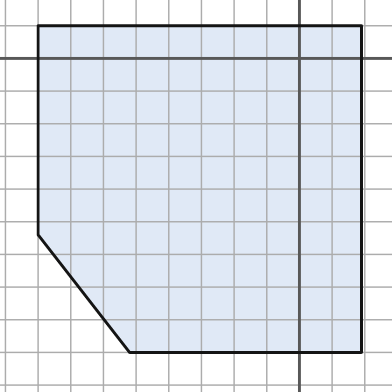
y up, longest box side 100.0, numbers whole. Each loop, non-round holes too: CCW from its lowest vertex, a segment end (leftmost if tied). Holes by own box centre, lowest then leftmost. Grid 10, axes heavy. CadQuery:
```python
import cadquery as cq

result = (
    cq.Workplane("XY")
    .moveTo(-52.0, -90.0)
    .lineTo(19.0, -90.0)
    .lineTo(19.0, 10.0)
    .lineTo(-80.0, 10.0)
    .lineTo(-80.0, -54.0)
    .close()
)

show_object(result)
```